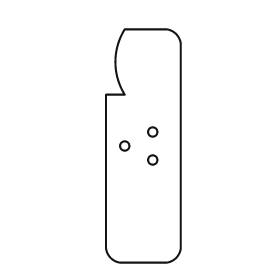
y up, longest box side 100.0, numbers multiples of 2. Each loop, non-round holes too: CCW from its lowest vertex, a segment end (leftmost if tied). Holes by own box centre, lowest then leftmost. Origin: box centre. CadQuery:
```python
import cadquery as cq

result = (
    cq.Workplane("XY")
    .moveTo(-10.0, -50.0)
    .lineTo(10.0, -50.0)
    .threePointArc((14.0, -48.0), (16.0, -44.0))
    .lineTo(16.0, 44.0)
    .threePointArc((14.0, 48.0), (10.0, 50.0))
    .lineTo(-8.0, 50.0)
    .threePointArc((-12.0, 36.0), (-8.0, 22.0))
    .lineTo(-16.0, 22.0)
    .lineTo(-16.0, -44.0)
    .threePointArc((-14.0, -48.0), (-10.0, -50.0))
    .close()
    .moveTo(4.0, -6.0)
    .circle(2.0)
    .moveTo(-8.0, 0.0)
    .circle(2.0)
    .moveTo(4.0, 6.0)
    .circle(2.0)
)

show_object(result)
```